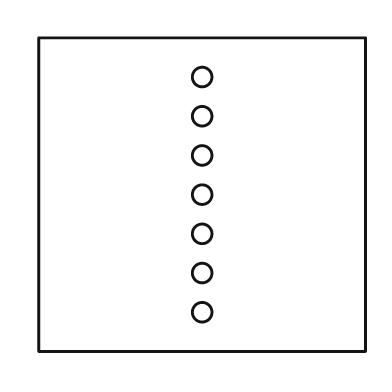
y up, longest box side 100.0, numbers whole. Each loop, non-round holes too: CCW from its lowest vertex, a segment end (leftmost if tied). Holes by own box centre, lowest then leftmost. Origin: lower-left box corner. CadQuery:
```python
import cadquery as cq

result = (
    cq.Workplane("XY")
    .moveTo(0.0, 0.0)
    .lineTo(100.0, 0.0)
    .lineTo(100.0, 96.0)
    .lineTo(0.0, 96.0)
    .close()
    .moveTo(50.0, 12.0)
    .circle(3.0)
    .moveTo(50.0, 24.0)
    .circle(3.0)
    .moveTo(50.0, 36.0)
    .circle(3.0)
    .moveTo(50.0, 48.0)
    .circle(3.0)
    .moveTo(50.0, 60.0)
    .circle(3.0)
    .moveTo(50.0, 72.0)
    .circle(3.0)
    .moveTo(50.0, 84.0)
    .circle(3.0)
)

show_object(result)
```